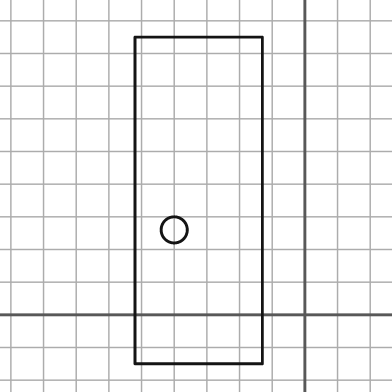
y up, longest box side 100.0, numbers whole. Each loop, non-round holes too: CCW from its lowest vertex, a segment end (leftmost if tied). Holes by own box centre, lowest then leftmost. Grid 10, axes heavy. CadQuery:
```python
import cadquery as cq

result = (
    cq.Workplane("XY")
    .moveTo(-52.0, -15.0)
    .lineTo(-13.0, -15.0)
    .lineTo(-13.0, 85.0)
    .lineTo(-52.0, 85.0)
    .close()
    .moveTo(-40.0, 26.0)
    .circle(4.0)
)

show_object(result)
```